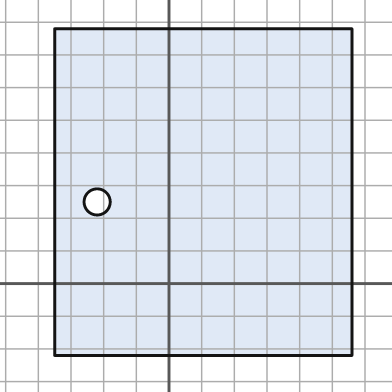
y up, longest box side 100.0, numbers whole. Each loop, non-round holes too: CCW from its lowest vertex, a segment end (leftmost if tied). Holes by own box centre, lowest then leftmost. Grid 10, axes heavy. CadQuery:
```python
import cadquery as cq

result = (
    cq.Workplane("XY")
    .moveTo(-35.0, -22.0)
    .lineTo(56.0, -22.0)
    .lineTo(56.0, 78.0)
    .lineTo(-35.0, 78.0)
    .close()
    .moveTo(-22.0, 25.0)
    .circle(4.0)
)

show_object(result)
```